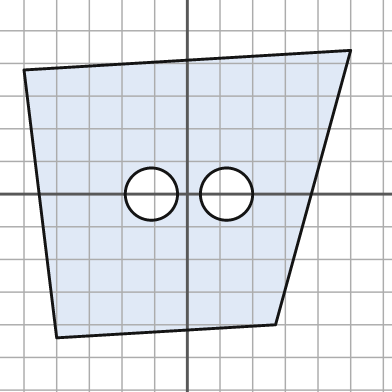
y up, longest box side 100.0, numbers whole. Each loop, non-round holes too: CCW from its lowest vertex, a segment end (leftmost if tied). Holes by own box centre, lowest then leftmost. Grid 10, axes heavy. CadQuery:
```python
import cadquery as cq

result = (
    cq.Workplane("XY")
    .moveTo(-40.0, -44.0)
    .lineTo(27.0, -40.0)
    .lineTo(50.0, 44.0)
    .lineTo(-50.0, 38.0)
    .close()
    .moveTo(-11.0, 0.0)
    .circle(8.0)
    .moveTo(12.0, 0.0)
    .circle(8.0)
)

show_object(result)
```